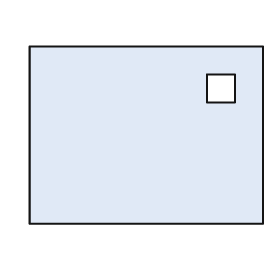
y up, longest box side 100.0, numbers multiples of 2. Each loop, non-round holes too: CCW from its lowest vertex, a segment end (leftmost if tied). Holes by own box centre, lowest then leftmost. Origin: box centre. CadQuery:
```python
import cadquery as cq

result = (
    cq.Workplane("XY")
    .moveTo(-50.0, -38.0)
    .lineTo(50.0, -38.0)
    .lineTo(50.0, 38.0)
    .lineTo(-50.0, 38.0)
    .close()
    .moveTo(26.0, 14.0)
    .lineTo(38.0, 14.0)
    .lineTo(38.0, 26.0)
    .lineTo(26.0, 26.0)
    .close()
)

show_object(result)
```